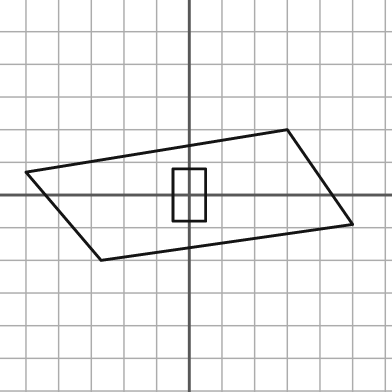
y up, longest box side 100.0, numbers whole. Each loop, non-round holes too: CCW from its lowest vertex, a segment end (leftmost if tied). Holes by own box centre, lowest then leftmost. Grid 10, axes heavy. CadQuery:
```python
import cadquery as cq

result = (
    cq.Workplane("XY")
    .moveTo(-27.0, -20.0)
    .lineTo(50.0, -9.0)
    .lineTo(30.0, 20.0)
    .lineTo(-50.0, 7.0)
    .close()
    .moveTo(-5.0, -8.0)
    .lineTo(5.0, -8.0)
    .lineTo(5.0, 8.0)
    .lineTo(-5.0, 8.0)
    .close()
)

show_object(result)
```